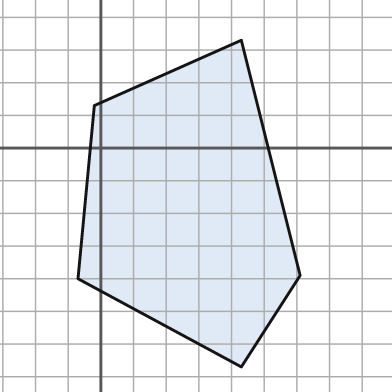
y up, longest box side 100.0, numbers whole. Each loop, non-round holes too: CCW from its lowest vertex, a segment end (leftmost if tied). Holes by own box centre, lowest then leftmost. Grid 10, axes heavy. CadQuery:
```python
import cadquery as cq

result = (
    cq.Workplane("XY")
    .moveTo(43.0, -67.0)
    .lineTo(61.0, -39.0)
    .lineTo(43.0, 33.0)
    .lineTo(-2.0, 13.0)
    .lineTo(-7.0, -40.0)
    .close()
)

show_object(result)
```